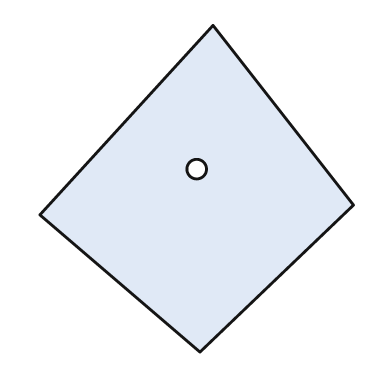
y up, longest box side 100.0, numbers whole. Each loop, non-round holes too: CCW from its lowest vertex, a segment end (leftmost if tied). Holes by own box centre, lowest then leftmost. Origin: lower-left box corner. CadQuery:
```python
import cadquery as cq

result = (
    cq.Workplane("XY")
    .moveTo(49.0, 0.0)
    .lineTo(96.0, 45.0)
    .lineTo(53.0, 100.0)
    .lineTo(0.0, 42.0)
    .close()
    .moveTo(48.0, 56.0)
    .circle(3.0)
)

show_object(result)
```